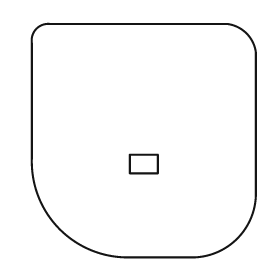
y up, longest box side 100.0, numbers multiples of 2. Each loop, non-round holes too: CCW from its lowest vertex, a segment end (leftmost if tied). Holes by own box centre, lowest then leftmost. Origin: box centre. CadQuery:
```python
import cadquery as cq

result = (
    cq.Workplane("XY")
    .moveTo(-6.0, -50.0)
    .lineTo(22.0, -50.0)
    .threePointArc((40.0, -42.0), (48.0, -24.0))
    .lineTo(48.0, 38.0)
    .threePointArc((44.0, 46.0), (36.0, 50.0))
    .lineTo(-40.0, 50.0)
    .threePointArc((-46.0, 48.0), (-48.0, 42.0))
    .lineTo(-48.0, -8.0)
    .threePointArc((-36.0, -38.0), (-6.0, -50.0))
    .close()
    .moveTo(-6.0, -14.0)
    .lineTo(6.0, -14.0)
    .lineTo(6.0, -6.0)
    .lineTo(-6.0, -6.0)
    .close()
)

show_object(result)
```